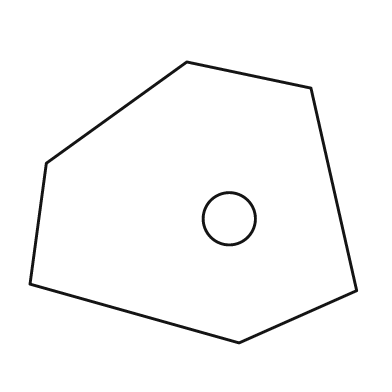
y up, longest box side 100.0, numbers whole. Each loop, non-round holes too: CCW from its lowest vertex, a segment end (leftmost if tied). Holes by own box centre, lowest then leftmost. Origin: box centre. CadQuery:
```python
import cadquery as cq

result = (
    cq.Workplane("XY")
    .moveTo(14.0, -43.0)
    .lineTo(50.0, -27.0)
    .lineTo(36.0, 35.0)
    .lineTo(-2.0, 43.0)
    .lineTo(-45.0, 12.0)
    .lineTo(-50.0, -25.0)
    .close()
    .moveTo(11.0, -5.0)
    .circle(8.0)
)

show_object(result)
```